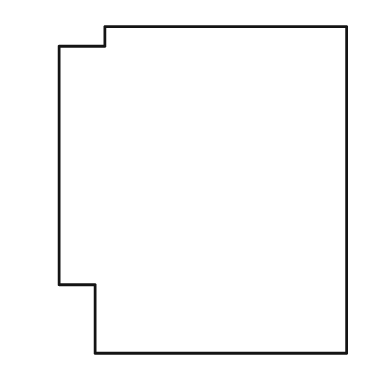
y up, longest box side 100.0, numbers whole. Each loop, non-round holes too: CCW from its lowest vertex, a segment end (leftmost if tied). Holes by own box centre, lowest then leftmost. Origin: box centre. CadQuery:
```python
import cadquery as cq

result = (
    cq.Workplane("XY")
    .moveTo(-33.0, -50.0)
    .lineTo(44.0, -50.0)
    .lineTo(44.0, 50.0)
    .lineTo(-30.0, 50.0)
    .lineTo(-30.0, 44.0)
    .lineTo(-44.0, 44.0)
    .lineTo(-44.0, -29.0)
    .lineTo(-33.0, -29.0)
    .close()
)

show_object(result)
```